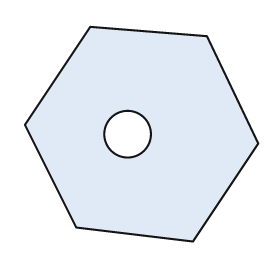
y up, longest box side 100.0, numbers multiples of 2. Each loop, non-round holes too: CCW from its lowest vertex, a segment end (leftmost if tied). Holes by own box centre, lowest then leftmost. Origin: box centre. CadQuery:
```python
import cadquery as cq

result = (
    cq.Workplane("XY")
    .moveTo(22.0, -46.0)
    .lineTo(50.0, -4.0)
    .lineTo(28.0, 42.0)
    .lineTo(-22.0, 46.0)
    .lineTo(-50.0, 4.0)
    .lineTo(-28.0, -40.0)
    .close()
    .moveTo(-6.0, 0.0)
    .circle(10.0)
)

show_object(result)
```